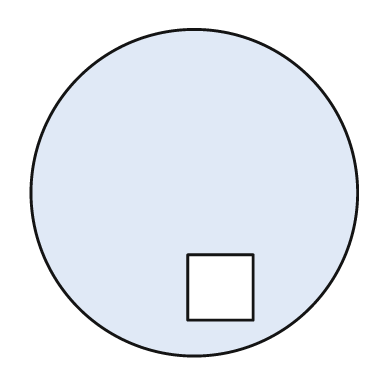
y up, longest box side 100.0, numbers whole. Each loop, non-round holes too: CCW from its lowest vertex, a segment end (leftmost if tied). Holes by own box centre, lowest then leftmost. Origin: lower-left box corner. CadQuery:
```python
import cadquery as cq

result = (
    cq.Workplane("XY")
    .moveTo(50.0, 50.0)
    .circle(50.0)
    .moveTo(48.0, 11.0)
    .lineTo(68.0, 11.0)
    .lineTo(68.0, 31.0)
    .lineTo(48.0, 31.0)
    .close()
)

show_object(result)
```